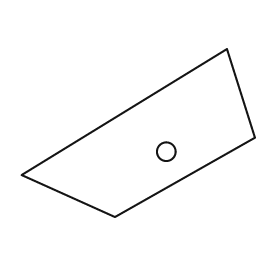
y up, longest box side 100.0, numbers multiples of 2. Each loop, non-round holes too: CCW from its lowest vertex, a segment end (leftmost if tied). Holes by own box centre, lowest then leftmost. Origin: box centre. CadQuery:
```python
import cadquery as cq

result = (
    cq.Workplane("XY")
    .moveTo(-10.0, -36.0)
    .lineTo(50.0, -2.0)
    .lineTo(38.0, 36.0)
    .lineTo(-50.0, -18.0)
    .close()
    .moveTo(12.0, -8.0)
    .circle(4.0)
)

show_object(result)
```